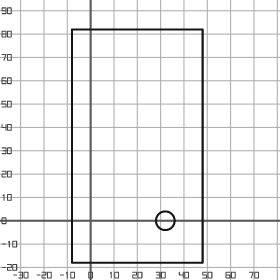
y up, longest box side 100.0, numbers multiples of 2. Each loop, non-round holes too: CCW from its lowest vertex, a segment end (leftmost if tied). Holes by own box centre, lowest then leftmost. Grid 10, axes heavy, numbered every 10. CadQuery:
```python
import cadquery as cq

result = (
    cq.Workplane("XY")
    .moveTo(-8.0, -18.0)
    .lineTo(48.0, -18.0)
    .lineTo(48.0, 82.0)
    .lineTo(-8.0, 82.0)
    .close()
    .moveTo(32.0, 0.0)
    .circle(4.0)
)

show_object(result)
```